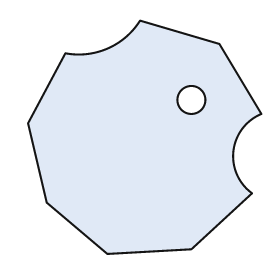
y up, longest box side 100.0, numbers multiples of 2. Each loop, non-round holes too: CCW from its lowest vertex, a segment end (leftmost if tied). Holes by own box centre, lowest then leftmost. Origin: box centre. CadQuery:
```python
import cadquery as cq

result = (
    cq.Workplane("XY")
    .moveTo(-16.0, -50.0)
    .lineTo(20.0, -48.0)
    .lineTo(46.0, -24.0)
    .threePointArc((38.0, -6.0), (50.0, 10.0))
    .lineTo(32.0, 40.0)
    .lineTo(-2.0, 50.0)
    .threePointArc((-16.0, 38.0), (-34.0, 36.0))
    .lineTo(-50.0, 6.0)
    .lineTo(-42.0, -28.0)
    .close()
    .moveTo(20.0, 16.0)
    .circle(6.0)
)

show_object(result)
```